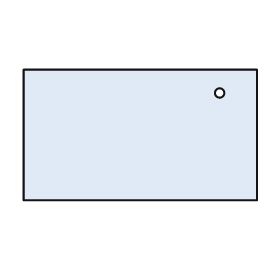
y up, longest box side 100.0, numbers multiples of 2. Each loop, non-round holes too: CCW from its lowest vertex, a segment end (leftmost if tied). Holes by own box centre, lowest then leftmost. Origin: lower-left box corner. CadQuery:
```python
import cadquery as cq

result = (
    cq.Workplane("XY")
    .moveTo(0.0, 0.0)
    .lineTo(100.0, 0.0)
    .lineTo(100.0, 56.0)
    .lineTo(0.0, 56.0)
    .close()
    .moveTo(84.0, 46.0)
    .circle(2.0)
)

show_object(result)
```